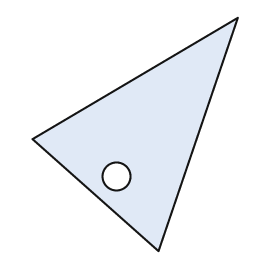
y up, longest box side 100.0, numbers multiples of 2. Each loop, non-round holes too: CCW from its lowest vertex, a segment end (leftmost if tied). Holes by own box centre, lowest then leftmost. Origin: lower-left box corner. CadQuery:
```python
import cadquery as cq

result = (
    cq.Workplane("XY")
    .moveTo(54.0, 0.0)
    .lineTo(88.0, 100.0)
    .lineTo(0.0, 48.0)
    .close()
    .moveTo(36.0, 32.0)
    .circle(6.0)
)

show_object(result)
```